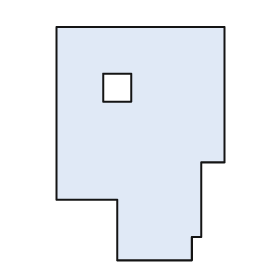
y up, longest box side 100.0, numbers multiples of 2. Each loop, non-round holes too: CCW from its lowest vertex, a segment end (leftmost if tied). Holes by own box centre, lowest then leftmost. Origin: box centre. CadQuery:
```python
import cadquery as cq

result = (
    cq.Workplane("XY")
    .moveTo(-10.0, -50.0)
    .lineTo(22.0, -50.0)
    .lineTo(22.0, -40.0)
    .lineTo(26.0, -40.0)
    .lineTo(26.0, -8.0)
    .lineTo(36.0, -8.0)
    .lineTo(36.0, 50.0)
    .lineTo(-36.0, 50.0)
    .lineTo(-36.0, -24.0)
    .lineTo(-10.0, -24.0)
    .close()
    .moveTo(-16.0, 18.0)
    .lineTo(-4.0, 18.0)
    .lineTo(-4.0, 30.0)
    .lineTo(-16.0, 30.0)
    .close()
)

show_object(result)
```